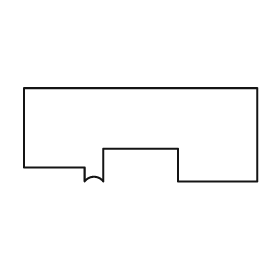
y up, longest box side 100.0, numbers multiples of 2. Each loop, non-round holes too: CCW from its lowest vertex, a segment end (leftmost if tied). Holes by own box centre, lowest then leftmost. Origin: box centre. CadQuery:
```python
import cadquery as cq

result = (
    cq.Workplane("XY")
    .moveTo(-24.0, -20.0)
    .threePointArc((-20.0, -18.0), (-16.0, -20.0))
    .lineTo(-16.0, -6.0)
    .lineTo(16.0, -6.0)
    .lineTo(16.0, -20.0)
    .lineTo(50.0, -20.0)
    .lineTo(50.0, 20.0)
    .lineTo(-50.0, 20.0)
    .lineTo(-50.0, -14.0)
    .lineTo(-24.0, -14.0)
    .close()
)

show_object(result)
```